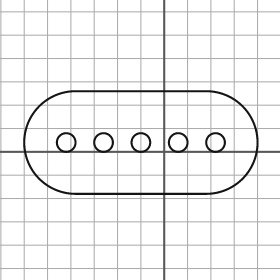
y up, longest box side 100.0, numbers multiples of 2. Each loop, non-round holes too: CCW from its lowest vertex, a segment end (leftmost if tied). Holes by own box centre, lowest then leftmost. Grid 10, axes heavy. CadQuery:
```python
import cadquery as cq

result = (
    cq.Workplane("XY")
    .moveTo(-38.0, -18.0)
    .lineTo(18.0, -18.0)
    .threePointArc((40.0, 4.0), (18.0, 26.0))
    .lineTo(-38.0, 26.0)
    .threePointArc((-60.0, 4.0), (-38.0, -18.0))
    .close()
    .moveTo(-42.0, 4.0)
    .circle(4.0)
    .moveTo(-26.0, 4.0)
    .circle(4.0)
    .moveTo(-10.0, 4.0)
    .circle(4.0)
    .moveTo(6.0, 4.0)
    .circle(4.0)
    .moveTo(22.0, 4.0)
    .circle(4.0)
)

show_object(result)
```